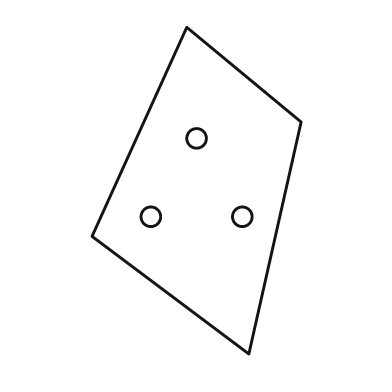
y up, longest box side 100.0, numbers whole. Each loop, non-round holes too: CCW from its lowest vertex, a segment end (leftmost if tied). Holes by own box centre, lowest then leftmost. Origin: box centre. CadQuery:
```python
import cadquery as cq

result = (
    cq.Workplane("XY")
    .moveTo(16.0, -50.0)
    .lineTo(32.0, 21.0)
    .lineTo(-3.0, 50.0)
    .lineTo(-32.0, -14.0)
    .close()
    .moveTo(-14.0, -8.0)
    .circle(3.0)
    .moveTo(14.0, -8.0)
    .circle(3.0)
    .moveTo(0.0, 16.0)
    .circle(3.0)
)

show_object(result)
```